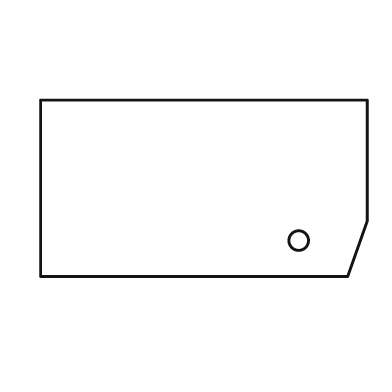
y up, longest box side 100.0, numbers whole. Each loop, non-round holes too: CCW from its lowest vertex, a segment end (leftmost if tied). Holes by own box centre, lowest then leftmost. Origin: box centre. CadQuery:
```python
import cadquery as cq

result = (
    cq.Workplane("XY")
    .moveTo(-50.0, -27.0)
    .lineTo(44.0, -27.0)
    .lineTo(50.0, -10.0)
    .lineTo(50.0, 27.0)
    .lineTo(-50.0, 27.0)
    .close()
    .moveTo(29.0, -16.0)
    .circle(3.0)
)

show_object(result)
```